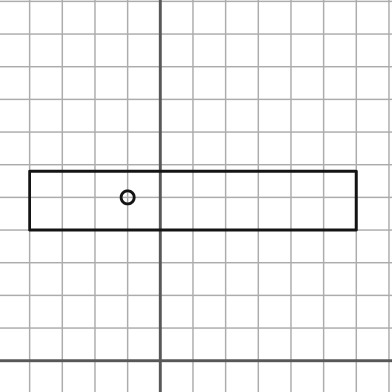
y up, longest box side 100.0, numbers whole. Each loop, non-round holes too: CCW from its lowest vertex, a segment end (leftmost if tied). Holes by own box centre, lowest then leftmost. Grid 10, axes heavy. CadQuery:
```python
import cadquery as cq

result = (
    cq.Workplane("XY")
    .moveTo(-40.0, 40.0)
    .lineTo(60.0, 40.0)
    .lineTo(60.0, 58.0)
    .lineTo(-40.0, 58.0)
    .close()
    .moveTo(-10.0, 50.0)
    .circle(2.0)
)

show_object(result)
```